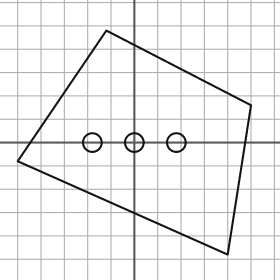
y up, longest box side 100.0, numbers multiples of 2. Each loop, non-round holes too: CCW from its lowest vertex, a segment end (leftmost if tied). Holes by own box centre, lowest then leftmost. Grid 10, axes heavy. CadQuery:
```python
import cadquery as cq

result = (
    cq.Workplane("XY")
    .moveTo(40.0, -48.0)
    .lineTo(50.0, 16.0)
    .lineTo(-12.0, 48.0)
    .lineTo(-50.0, -8.0)
    .close()
    .moveTo(-18.0, 0.0)
    .circle(4.0)
    .moveTo(0.0, 0.0)
    .circle(4.0)
    .moveTo(18.0, 0.0)
    .circle(4.0)
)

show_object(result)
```